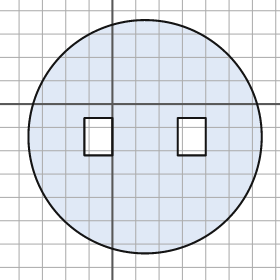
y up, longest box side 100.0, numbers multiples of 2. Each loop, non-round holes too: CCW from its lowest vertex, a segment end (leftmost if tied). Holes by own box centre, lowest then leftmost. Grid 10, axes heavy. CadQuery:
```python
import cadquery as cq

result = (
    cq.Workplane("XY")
    .moveTo(14.0, -14.0)
    .circle(50.0)
    .moveTo(-12.0, -22.0)
    .lineTo(0.0, -22.0)
    .lineTo(0.0, -6.0)
    .lineTo(-12.0, -6.0)
    .close()
    .moveTo(28.0, -22.0)
    .lineTo(40.0, -22.0)
    .lineTo(40.0, -6.0)
    .lineTo(28.0, -6.0)
    .close()
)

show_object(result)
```